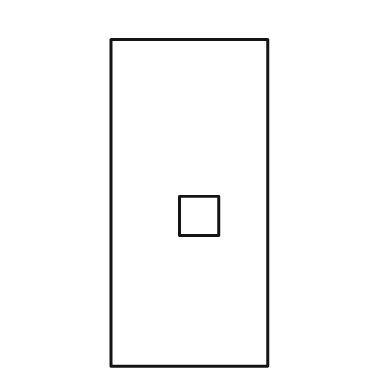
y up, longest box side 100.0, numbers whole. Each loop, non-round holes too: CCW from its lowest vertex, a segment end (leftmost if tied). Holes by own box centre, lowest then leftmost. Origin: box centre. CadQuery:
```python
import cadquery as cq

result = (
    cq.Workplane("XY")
    .moveTo(-24.0, -50.0)
    .lineTo(24.0, -50.0)
    .lineTo(24.0, 50.0)
    .lineTo(-24.0, 50.0)
    .close()
    .moveTo(-3.0, -10.0)
    .lineTo(9.0, -10.0)
    .lineTo(9.0, 2.0)
    .lineTo(-3.0, 2.0)
    .close()
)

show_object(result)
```